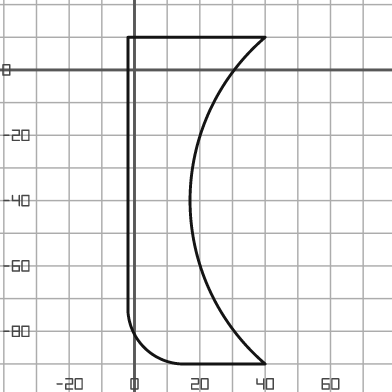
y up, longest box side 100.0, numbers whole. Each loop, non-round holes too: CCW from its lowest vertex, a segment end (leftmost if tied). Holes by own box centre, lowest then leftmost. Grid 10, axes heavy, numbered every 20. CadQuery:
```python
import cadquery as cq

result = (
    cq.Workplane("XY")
    .moveTo(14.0, -90.0)
    .lineTo(40.0, -90.0)
    .threePointArc((17.0, -40.0), (40.0, 10.0))
    .lineTo(-2.0, 10.0)
    .lineTo(-2.0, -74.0)
    .threePointArc((3.0, -85.0), (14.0, -90.0))
    .close()
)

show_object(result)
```